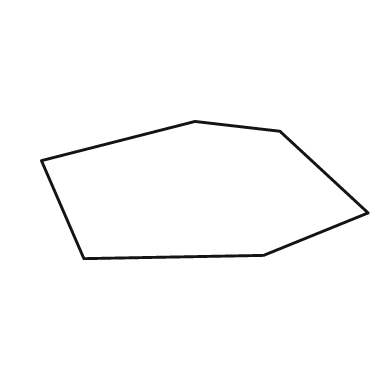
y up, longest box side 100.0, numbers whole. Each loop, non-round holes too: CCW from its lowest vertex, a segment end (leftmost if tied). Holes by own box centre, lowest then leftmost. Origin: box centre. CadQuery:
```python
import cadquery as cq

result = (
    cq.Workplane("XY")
    .moveTo(-37.0, -21.0)
    .lineTo(18.0, -20.0)
    .lineTo(50.0, -7.0)
    .lineTo(23.0, 18.0)
    .lineTo(-3.0, 21.0)
    .lineTo(-50.0, 9.0)
    .close()
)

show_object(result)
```